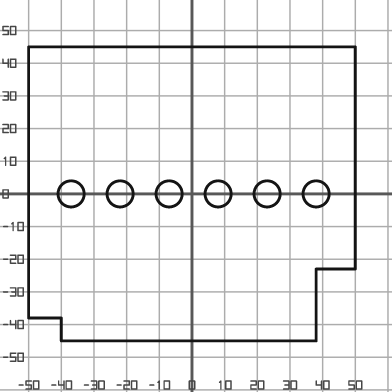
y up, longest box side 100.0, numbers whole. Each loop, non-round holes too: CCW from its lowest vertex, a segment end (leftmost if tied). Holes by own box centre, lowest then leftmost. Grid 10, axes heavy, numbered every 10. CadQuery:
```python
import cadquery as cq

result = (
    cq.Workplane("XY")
    .moveTo(-40.0, -45.0)
    .lineTo(38.0, -45.0)
    .lineTo(38.0, -23.0)
    .lineTo(50.0, -23.0)
    .lineTo(50.0, 45.0)
    .lineTo(-50.0, 45.0)
    .lineTo(-50.0, -38.0)
    .lineTo(-40.0, -38.0)
    .close()
    .moveTo(-37.0, 0.0)
    .circle(4.0)
    .moveTo(-22.0, 0.0)
    .circle(4.0)
    .moveTo(-7.0, 0.0)
    .circle(4.0)
    .moveTo(8.0, 0.0)
    .circle(4.0)
    .moveTo(23.0, 0.0)
    .circle(4.0)
    .moveTo(38.0, 0.0)
    .circle(4.0)
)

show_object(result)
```